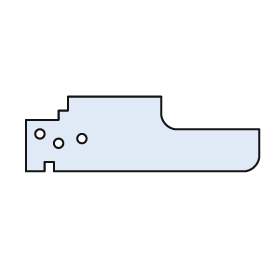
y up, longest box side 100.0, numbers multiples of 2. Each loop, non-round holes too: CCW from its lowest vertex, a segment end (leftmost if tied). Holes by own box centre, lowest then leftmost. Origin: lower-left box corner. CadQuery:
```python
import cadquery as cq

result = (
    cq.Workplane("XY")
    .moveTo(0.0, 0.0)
    .lineTo(8.0, 0.0)
    .lineTo(8.0, 4.0)
    .lineTo(12.0, 4.0)
    .lineTo(12.0, 0.0)
    .lineTo(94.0, 0.0)
    .threePointArc((98.0, 2.0), (100.0, 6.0))
    .lineTo(100.0, 18.0)
    .lineTo(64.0, 18.0)
    .threePointArc((60.0, 20.0), (58.0, 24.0))
    .lineTo(58.0, 32.0)
    .lineTo(18.0, 32.0)
    .lineTo(18.0, 26.0)
    .lineTo(14.0, 26.0)
    .lineTo(14.0, 22.0)
    .lineTo(0.0, 22.0)
    .close()
    .moveTo(14.0, 12.0)
    .circle(2.0)
    .moveTo(24.0, 14.0)
    .circle(2.0)
    .moveTo(6.0, 16.0)
    .circle(2.0)
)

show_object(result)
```